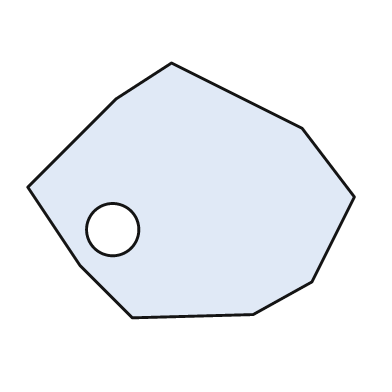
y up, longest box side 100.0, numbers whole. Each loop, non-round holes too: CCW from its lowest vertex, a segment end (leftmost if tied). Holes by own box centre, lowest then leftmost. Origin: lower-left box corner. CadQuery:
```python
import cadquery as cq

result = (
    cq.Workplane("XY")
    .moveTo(32.0, 0.0)
    .lineTo(69.0, 1.0)
    .lineTo(87.0, 11.0)
    .lineTo(100.0, 37.0)
    .lineTo(84.0, 58.0)
    .lineTo(44.0, 78.0)
    .lineTo(27.0, 67.0)
    .lineTo(0.0, 40.0)
    .lineTo(16.0, 16.0)
    .close()
    .moveTo(26.0, 27.0)
    .circle(8.0)
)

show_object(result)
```